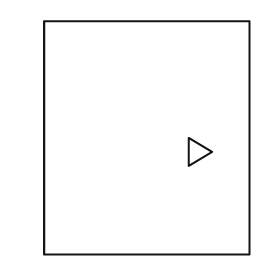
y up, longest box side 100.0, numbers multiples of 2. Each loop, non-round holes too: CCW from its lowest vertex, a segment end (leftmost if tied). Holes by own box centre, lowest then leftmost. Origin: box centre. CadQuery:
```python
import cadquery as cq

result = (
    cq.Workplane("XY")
    .moveTo(-44.0, -50.0)
    .lineTo(44.0, -50.0)
    .lineTo(44.0, 50.0)
    .lineTo(-44.0, 50.0)
    .close()
    .moveTo(18.0, -12.0)
    .lineTo(28.0, -6.0)
    .lineTo(18.0, 0.0)
    .close()
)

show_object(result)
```